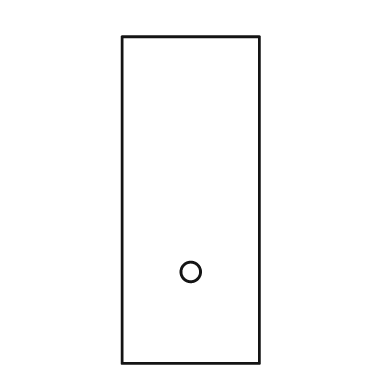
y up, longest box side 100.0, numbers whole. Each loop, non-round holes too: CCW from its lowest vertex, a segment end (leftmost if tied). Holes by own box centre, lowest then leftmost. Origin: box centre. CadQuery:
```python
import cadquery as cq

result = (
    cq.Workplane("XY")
    .moveTo(-21.0, -50.0)
    .lineTo(21.0, -50.0)
    .lineTo(21.0, 50.0)
    .lineTo(-21.0, 50.0)
    .close()
    .moveTo(0.0, -22.0)
    .circle(3.0)
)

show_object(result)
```